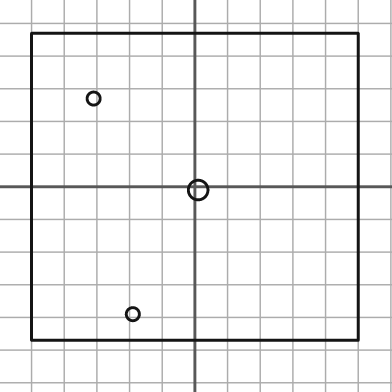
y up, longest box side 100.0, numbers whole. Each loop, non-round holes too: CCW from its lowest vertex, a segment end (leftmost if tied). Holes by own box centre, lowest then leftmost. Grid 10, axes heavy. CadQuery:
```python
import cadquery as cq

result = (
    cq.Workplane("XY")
    .moveTo(-50.0, -47.0)
    .lineTo(50.0, -47.0)
    .lineTo(50.0, 47.0)
    .lineTo(-50.0, 47.0)
    .close()
    .moveTo(-19.0, -39.0)
    .circle(2.0)
    .moveTo(1.0, -1.0)
    .circle(3.0)
    .moveTo(-31.0, 27.0)
    .circle(2.0)
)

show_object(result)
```